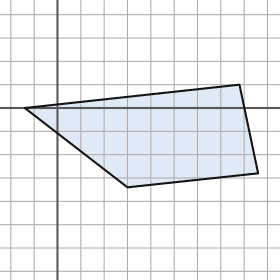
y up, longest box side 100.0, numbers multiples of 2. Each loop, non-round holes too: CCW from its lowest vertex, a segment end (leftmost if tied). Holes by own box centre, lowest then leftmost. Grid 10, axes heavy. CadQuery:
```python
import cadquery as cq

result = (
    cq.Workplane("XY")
    .moveTo(30.0, -34.0)
    .lineTo(86.0, -28.0)
    .lineTo(78.0, 10.0)
    .lineTo(-14.0, 0.0)
    .close()
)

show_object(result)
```